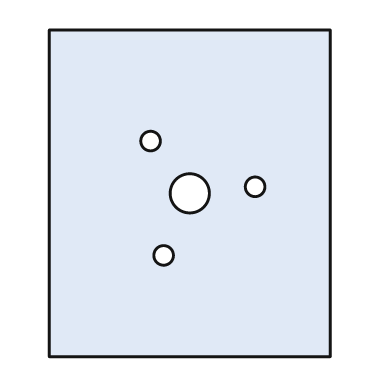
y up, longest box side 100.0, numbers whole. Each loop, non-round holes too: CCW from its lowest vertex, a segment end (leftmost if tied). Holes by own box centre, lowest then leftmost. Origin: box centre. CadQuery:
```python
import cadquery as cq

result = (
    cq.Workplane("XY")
    .moveTo(-43.0, -50.0)
    .lineTo(43.0, -50.0)
    .lineTo(43.0, 50.0)
    .lineTo(-43.0, 50.0)
    .close()
    .moveTo(-8.0, -19.0)
    .circle(3.0)
    .moveTo(0.0, 0.0)
    .circle(6.0)
    .moveTo(20.0, 2.0)
    .circle(3.0)
    .moveTo(-12.0, 16.0)
    .circle(3.0)
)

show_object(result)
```